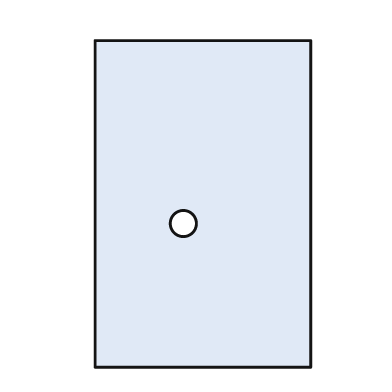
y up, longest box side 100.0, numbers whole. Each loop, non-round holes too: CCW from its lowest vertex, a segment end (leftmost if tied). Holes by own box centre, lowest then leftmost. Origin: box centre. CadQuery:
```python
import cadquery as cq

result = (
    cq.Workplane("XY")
    .moveTo(-33.0, -50.0)
    .lineTo(33.0, -50.0)
    .lineTo(33.0, 50.0)
    .lineTo(-33.0, 50.0)
    .close()
    .moveTo(-6.0, -6.0)
    .circle(4.0)
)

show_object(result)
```